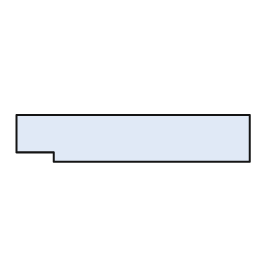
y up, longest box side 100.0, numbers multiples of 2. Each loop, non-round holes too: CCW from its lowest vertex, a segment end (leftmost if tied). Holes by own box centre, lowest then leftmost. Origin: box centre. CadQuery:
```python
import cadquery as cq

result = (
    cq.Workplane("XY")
    .moveTo(-34.0, -10.0)
    .lineTo(50.0, -10.0)
    .lineTo(50.0, 10.0)
    .lineTo(-50.0, 10.0)
    .lineTo(-50.0, -6.0)
    .lineTo(-34.0, -6.0)
    .close()
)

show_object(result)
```